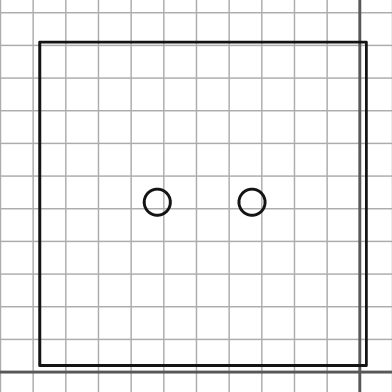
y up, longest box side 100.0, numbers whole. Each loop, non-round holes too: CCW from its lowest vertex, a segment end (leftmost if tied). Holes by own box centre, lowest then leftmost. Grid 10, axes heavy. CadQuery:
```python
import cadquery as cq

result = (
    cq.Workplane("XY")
    .moveTo(-98.0, 2.0)
    .lineTo(2.0, 2.0)
    .lineTo(2.0, 101.0)
    .lineTo(-98.0, 101.0)
    .close()
    .moveTo(-62.0, 52.0)
    .circle(4.0)
    .moveTo(-33.0, 52.0)
    .circle(4.0)
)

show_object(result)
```